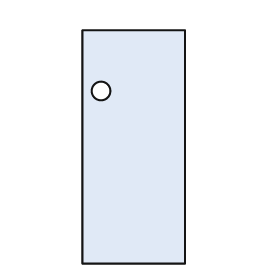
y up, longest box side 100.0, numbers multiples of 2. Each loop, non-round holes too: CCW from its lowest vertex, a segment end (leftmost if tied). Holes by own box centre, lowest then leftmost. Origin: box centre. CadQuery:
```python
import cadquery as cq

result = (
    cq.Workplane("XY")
    .moveTo(-22.0, -50.0)
    .lineTo(22.0, -50.0)
    .lineTo(22.0, 50.0)
    .lineTo(-22.0, 50.0)
    .close()
    .moveTo(-14.0, 24.0)
    .circle(4.0)
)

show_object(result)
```